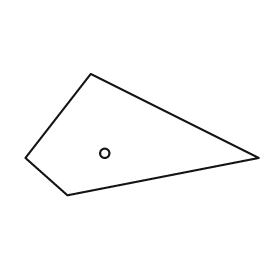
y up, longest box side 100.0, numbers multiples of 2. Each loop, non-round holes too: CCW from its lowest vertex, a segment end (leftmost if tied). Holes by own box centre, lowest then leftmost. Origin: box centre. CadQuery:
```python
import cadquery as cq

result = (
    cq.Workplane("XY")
    .moveTo(-32.0, -26.0)
    .lineTo(50.0, -10.0)
    .lineTo(-22.0, 26.0)
    .lineTo(-50.0, -10.0)
    .close()
    .moveTo(-16.0, -8.0)
    .circle(2.0)
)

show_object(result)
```